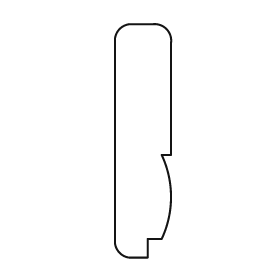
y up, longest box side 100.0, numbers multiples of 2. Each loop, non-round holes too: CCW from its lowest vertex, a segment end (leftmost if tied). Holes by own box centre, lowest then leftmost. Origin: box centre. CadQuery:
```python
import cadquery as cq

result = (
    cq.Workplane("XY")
    .moveTo(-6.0, -50.0)
    .lineTo(2.0, -50.0)
    .lineTo(2.0, -42.0)
    .lineTo(8.0, -42.0)
    .threePointArc((12.0, -24.0), (8.0, -6.0))
    .lineTo(12.0, -6.0)
    .lineTo(12.0, 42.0)
    .threePointArc((10.0, 48.0), (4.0, 50.0))
    .lineTo(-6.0, 50.0)
    .threePointArc((-10.0, 48.0), (-12.0, 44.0))
    .lineTo(-12.0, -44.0)
    .threePointArc((-10.0, -48.0), (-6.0, -50.0))
    .close()
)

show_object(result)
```